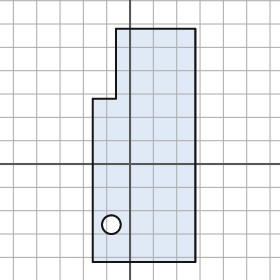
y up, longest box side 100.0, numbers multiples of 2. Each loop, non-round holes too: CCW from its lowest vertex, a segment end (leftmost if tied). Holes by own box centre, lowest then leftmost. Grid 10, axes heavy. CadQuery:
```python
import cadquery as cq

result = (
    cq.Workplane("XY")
    .moveTo(-16.0, -42.0)
    .lineTo(28.0, -42.0)
    .lineTo(28.0, 58.0)
    .lineTo(-6.0, 58.0)
    .lineTo(-6.0, 28.0)
    .lineTo(-16.0, 28.0)
    .close()
    .moveTo(-8.0, -26.0)
    .circle(4.0)
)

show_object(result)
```